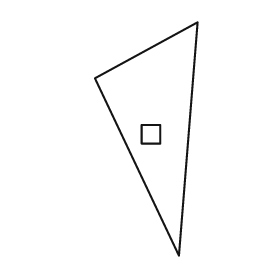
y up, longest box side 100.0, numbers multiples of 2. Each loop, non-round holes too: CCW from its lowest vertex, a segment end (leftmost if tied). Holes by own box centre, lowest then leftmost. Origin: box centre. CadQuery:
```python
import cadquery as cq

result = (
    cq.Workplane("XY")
    .moveTo(14.0, -50.0)
    .lineTo(22.0, 50.0)
    .lineTo(-22.0, 26.0)
    .close()
    .moveTo(-2.0, -2.0)
    .lineTo(6.0, -2.0)
    .lineTo(6.0, 6.0)
    .lineTo(-2.0, 6.0)
    .close()
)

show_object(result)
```